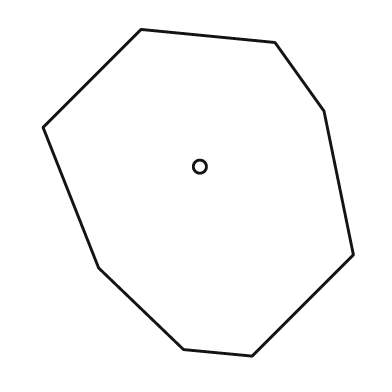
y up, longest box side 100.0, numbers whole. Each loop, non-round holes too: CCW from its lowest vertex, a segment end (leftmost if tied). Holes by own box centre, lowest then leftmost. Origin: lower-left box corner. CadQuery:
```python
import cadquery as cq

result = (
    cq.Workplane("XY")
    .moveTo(64.0, 0.0)
    .lineTo(95.0, 31.0)
    .lineTo(86.0, 75.0)
    .lineTo(71.0, 96.0)
    .lineTo(30.0, 100.0)
    .lineTo(0.0, 70.0)
    .lineTo(17.0, 27.0)
    .lineTo(43.0, 2.0)
    .close()
    .moveTo(48.0, 58.0)
    .circle(2.0)
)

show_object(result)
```